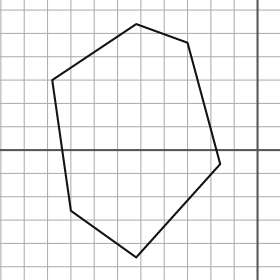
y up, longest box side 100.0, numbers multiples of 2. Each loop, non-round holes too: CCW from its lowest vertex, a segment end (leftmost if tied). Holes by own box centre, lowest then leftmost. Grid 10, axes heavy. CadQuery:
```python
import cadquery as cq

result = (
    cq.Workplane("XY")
    .moveTo(-52.0, -46.0)
    .lineTo(-16.0, -6.0)
    .lineTo(-30.0, 46.0)
    .lineTo(-52.0, 54.0)
    .lineTo(-88.0, 30.0)
    .lineTo(-80.0, -26.0)
    .close()
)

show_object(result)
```